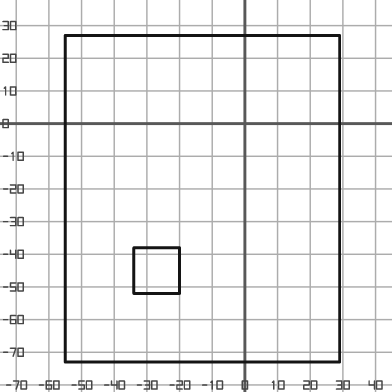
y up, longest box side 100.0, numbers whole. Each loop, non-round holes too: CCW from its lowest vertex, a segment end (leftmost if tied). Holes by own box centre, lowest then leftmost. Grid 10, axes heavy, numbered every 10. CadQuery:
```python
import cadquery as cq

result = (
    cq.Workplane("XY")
    .moveTo(-55.0, -73.0)
    .lineTo(29.0, -73.0)
    .lineTo(29.0, 27.0)
    .lineTo(-55.0, 27.0)
    .close()
    .moveTo(-34.0, -52.0)
    .lineTo(-20.0, -52.0)
    .lineTo(-20.0, -38.0)
    .lineTo(-34.0, -38.0)
    .close()
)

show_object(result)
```